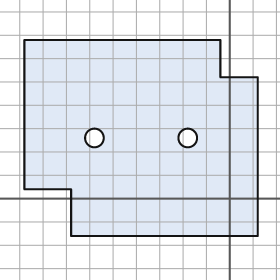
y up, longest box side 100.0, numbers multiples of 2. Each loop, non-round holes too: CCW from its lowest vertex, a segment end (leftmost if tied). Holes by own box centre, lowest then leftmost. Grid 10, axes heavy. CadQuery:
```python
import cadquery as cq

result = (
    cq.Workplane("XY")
    .moveTo(-68.0, -16.0)
    .lineTo(12.0, -16.0)
    .lineTo(12.0, 52.0)
    .lineTo(-4.0, 52.0)
    .lineTo(-4.0, 68.0)
    .lineTo(-88.0, 68.0)
    .lineTo(-88.0, 4.0)
    .lineTo(-68.0, 4.0)
    .close()
    .moveTo(-58.0, 26.0)
    .circle(4.0)
    .moveTo(-18.0, 26.0)
    .circle(4.0)
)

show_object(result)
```